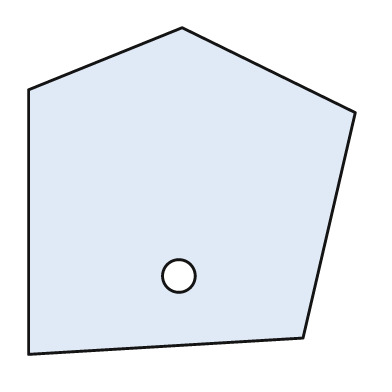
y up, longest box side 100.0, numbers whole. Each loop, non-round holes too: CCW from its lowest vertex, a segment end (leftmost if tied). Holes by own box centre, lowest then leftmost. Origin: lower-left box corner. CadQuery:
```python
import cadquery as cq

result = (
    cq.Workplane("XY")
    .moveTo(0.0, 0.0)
    .lineTo(84.0, 5.0)
    .lineTo(100.0, 74.0)
    .lineTo(47.0, 100.0)
    .lineTo(0.0, 81.0)
    .close()
    .moveTo(46.0, 24.0)
    .circle(5.0)
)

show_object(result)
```